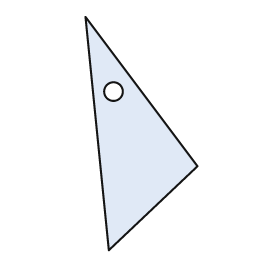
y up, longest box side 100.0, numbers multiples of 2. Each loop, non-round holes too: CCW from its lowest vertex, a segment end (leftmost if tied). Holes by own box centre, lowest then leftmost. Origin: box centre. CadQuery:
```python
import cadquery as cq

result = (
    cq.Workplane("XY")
    .moveTo(-14.0, -50.0)
    .lineTo(24.0, -14.0)
    .lineTo(-24.0, 50.0)
    .close()
    .moveTo(-12.0, 18.0)
    .circle(4.0)
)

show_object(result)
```